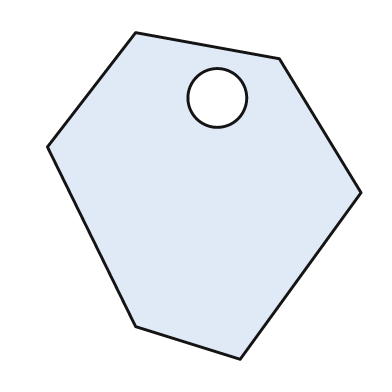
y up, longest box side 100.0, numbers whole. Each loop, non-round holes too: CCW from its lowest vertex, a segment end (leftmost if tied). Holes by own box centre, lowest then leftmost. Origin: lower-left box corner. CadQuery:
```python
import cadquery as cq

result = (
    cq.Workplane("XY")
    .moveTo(59.0, 0.0)
    .lineTo(96.0, 51.0)
    .lineTo(71.0, 92.0)
    .lineTo(27.0, 100.0)
    .lineTo(0.0, 65.0)
    .lineTo(27.0, 10.0)
    .close()
    .moveTo(52.0, 80.0)
    .circle(9.0)
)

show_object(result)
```